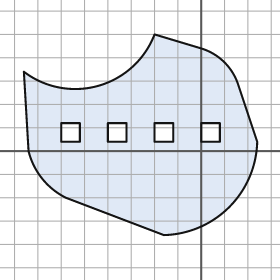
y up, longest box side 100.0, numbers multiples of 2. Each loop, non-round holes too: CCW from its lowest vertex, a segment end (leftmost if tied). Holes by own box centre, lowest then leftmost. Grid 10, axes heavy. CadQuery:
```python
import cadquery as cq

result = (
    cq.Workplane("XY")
    .moveTo(-16.0, -36.0)
    .threePointArc((12.0, -24.0), (24.0, 4.0))
    .lineTo(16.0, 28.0)
    .threePointArc((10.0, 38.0), (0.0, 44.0))
    .lineTo(-20.0, 50.0)
    .threePointArc((-44.0, 28.0), (-76.0, 34.0))
    .lineTo(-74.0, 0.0)
    .threePointArc((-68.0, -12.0), (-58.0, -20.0))
    .close()
    .moveTo(-60.0, 4.0)
    .lineTo(-52.0, 4.0)
    .lineTo(-52.0, 12.0)
    .lineTo(-60.0, 12.0)
    .close()
    .moveTo(-40.0, 4.0)
    .lineTo(-32.0, 4.0)
    .lineTo(-32.0, 12.0)
    .lineTo(-40.0, 12.0)
    .close()
    .moveTo(-20.0, 4.0)
    .lineTo(-12.0, 4.0)
    .lineTo(-12.0, 12.0)
    .lineTo(-20.0, 12.0)
    .close()
    .moveTo(0.0, 4.0)
    .lineTo(8.0, 4.0)
    .lineTo(8.0, 12.0)
    .lineTo(0.0, 12.0)
    .close()
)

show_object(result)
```